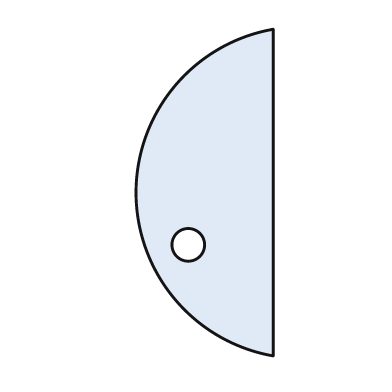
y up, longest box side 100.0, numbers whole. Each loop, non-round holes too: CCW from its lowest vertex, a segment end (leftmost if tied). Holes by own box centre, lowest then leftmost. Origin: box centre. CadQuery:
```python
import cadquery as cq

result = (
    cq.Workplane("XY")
    .moveTo(21.0, -50.0)
    .lineTo(21.0, 50.0)
    .threePointArc((-21.0, 0.0), (21.0, -50.0))
    .close()
    .moveTo(-5.0, -16.0)
    .circle(5.0)
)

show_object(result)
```